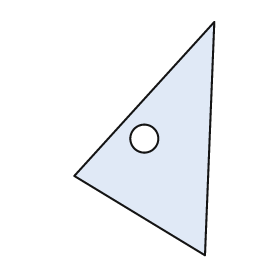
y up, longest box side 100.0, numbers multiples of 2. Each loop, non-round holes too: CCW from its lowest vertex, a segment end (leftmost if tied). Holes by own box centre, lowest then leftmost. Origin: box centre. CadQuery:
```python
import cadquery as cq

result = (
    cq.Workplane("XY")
    .moveTo(26.0, -50.0)
    .lineTo(30.0, 50.0)
    .lineTo(-30.0, -16.0)
    .close()
    .moveTo(0.0, 0.0)
    .circle(6.0)
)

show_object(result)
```